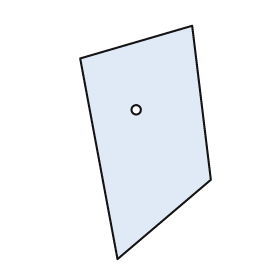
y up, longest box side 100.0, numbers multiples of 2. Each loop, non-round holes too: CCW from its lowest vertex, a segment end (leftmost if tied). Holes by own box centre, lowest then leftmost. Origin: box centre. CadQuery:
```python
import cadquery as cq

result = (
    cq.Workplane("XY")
    .moveTo(-12.0, -50.0)
    .lineTo(28.0, -16.0)
    .lineTo(20.0, 50.0)
    .lineTo(-28.0, 36.0)
    .close()
    .moveTo(-4.0, 14.0)
    .circle(2.0)
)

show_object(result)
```